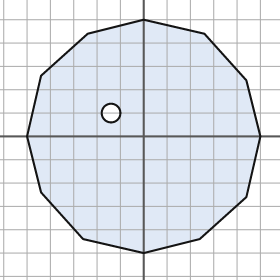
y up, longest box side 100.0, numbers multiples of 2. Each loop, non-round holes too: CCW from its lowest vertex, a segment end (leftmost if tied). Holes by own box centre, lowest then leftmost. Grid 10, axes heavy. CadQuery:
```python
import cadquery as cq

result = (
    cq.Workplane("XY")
    .moveTo(0.0, -50.0)
    .lineTo(24.0, -44.0)
    .lineTo(44.0, -26.0)
    .lineTo(50.0, 0.0)
    .lineTo(44.0, 24.0)
    .lineTo(26.0, 44.0)
    .lineTo(0.0, 50.0)
    .lineTo(-24.0, 44.0)
    .lineTo(-44.0, 26.0)
    .lineTo(-50.0, 0.0)
    .lineTo(-44.0, -24.0)
    .lineTo(-26.0, -44.0)
    .close()
    .moveTo(-14.0, 10.0)
    .circle(4.0)
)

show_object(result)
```